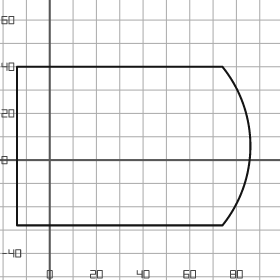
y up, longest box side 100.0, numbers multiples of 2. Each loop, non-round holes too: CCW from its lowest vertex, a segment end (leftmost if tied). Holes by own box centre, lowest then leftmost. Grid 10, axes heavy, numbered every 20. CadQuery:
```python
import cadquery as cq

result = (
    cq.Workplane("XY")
    .moveTo(-14.0, -28.0)
    .lineTo(74.0, -28.0)
    .threePointArc((86.0, 6.0), (74.0, 40.0))
    .lineTo(-14.0, 40.0)
    .close()
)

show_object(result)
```